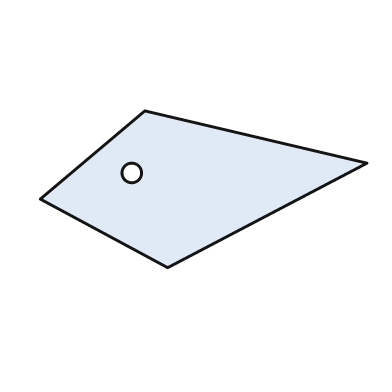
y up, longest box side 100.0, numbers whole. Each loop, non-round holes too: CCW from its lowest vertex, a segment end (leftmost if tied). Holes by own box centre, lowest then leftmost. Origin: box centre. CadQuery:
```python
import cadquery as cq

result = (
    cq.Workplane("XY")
    .moveTo(-11.0, -24.0)
    .lineTo(50.0, 8.0)
    .lineTo(-18.0, 24.0)
    .lineTo(-50.0, -3.0)
    .close()
    .moveTo(-22.0, 5.0)
    .circle(3.0)
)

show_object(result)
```